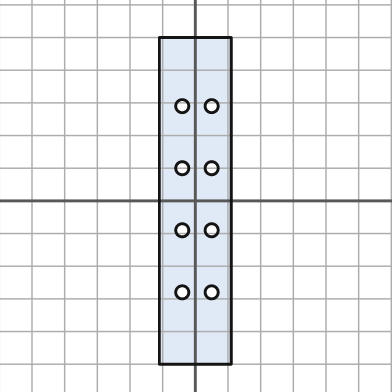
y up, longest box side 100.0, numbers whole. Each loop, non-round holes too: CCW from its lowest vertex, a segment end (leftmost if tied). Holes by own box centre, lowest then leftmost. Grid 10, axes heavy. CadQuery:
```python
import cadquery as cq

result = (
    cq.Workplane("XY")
    .moveTo(-11.0, -50.0)
    .lineTo(11.0, -50.0)
    .lineTo(11.0, 50.0)
    .lineTo(-11.0, 50.0)
    .close()
    .moveTo(-4.0, -28.0)
    .circle(2.0)
    .moveTo(5.0, -28.0)
    .circle(2.0)
    .moveTo(-4.0, -9.0)
    .circle(2.0)
    .moveTo(5.0, -9.0)
    .circle(2.0)
    .moveTo(-4.0, 10.0)
    .circle(2.0)
    .moveTo(5.0, 10.0)
    .circle(2.0)
    .moveTo(-4.0, 29.0)
    .circle(2.0)
    .moveTo(5.0, 29.0)
    .circle(2.0)
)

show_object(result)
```